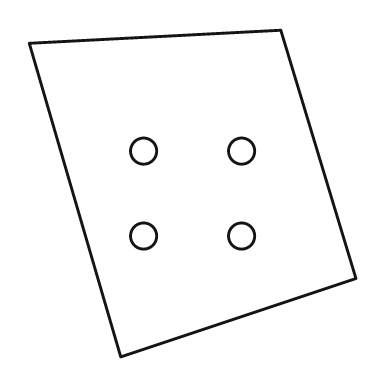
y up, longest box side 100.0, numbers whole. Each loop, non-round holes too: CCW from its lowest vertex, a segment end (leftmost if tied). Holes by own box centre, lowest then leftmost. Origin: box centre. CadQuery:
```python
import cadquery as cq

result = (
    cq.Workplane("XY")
    .moveTo(-22.0, -50.0)
    .lineTo(50.0, -26.0)
    .lineTo(27.0, 50.0)
    .lineTo(-50.0, 46.0)
    .close()
    .moveTo(-15.0, -13.0)
    .circle(4.0)
    .moveTo(15.0, -13.0)
    .circle(4.0)
    .moveTo(-15.0, 13.0)
    .circle(4.0)
    .moveTo(15.0, 13.0)
    .circle(4.0)
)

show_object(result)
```